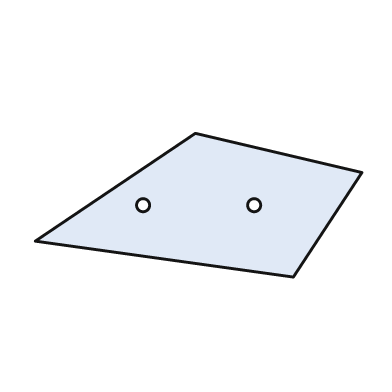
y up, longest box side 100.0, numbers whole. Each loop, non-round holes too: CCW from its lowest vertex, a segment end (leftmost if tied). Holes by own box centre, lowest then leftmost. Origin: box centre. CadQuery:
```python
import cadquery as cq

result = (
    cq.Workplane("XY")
    .moveTo(29.0, -22.0)
    .lineTo(50.0, 10.0)
    .lineTo(-1.0, 22.0)
    .lineTo(-50.0, -11.0)
    .close()
    .moveTo(-17.0, 0.0)
    .circle(2.0)
    .moveTo(17.0, 0.0)
    .circle(2.0)
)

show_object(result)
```